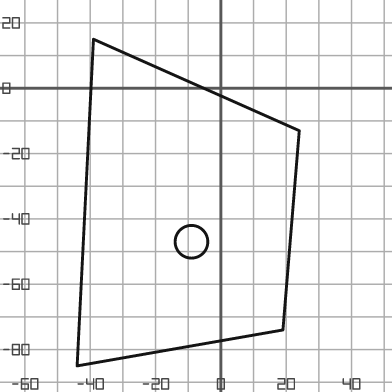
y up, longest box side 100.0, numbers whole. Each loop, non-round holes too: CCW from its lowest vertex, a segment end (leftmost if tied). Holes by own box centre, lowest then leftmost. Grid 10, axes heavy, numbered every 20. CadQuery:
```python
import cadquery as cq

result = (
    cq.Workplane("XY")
    .moveTo(-44.0, -85.0)
    .lineTo(19.0, -74.0)
    .lineTo(24.0, -13.0)
    .lineTo(-39.0, 15.0)
    .close()
    .moveTo(-9.0, -47.0)
    .circle(5.0)
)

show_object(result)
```